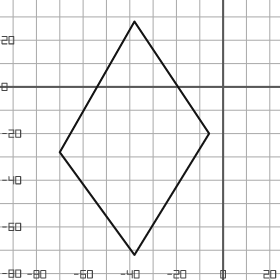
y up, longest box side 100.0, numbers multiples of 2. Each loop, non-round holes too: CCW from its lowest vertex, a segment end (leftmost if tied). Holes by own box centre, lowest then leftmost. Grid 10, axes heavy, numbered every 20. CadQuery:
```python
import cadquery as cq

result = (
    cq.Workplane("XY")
    .moveTo(-38.0, -72.0)
    .lineTo(-6.0, -20.0)
    .lineTo(-38.0, 28.0)
    .lineTo(-70.0, -28.0)
    .close()
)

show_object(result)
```